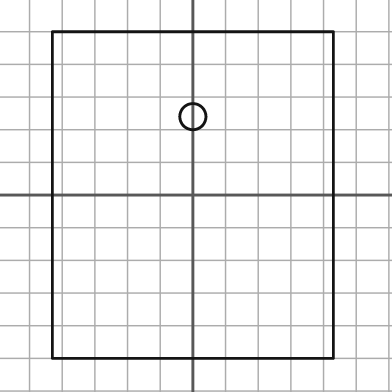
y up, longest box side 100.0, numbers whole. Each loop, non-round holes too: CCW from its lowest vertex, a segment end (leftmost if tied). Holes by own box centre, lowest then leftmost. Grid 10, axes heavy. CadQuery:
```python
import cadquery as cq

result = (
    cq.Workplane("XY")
    .moveTo(-43.0, -50.0)
    .lineTo(43.0, -50.0)
    .lineTo(43.0, 50.0)
    .lineTo(-43.0, 50.0)
    .close()
    .moveTo(0.0, 24.0)
    .circle(4.0)
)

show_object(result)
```